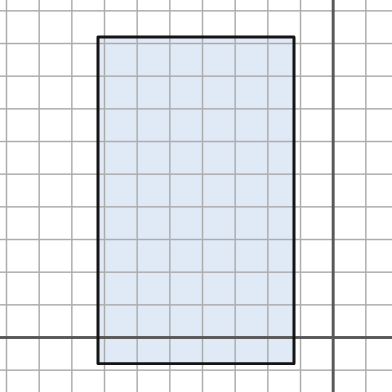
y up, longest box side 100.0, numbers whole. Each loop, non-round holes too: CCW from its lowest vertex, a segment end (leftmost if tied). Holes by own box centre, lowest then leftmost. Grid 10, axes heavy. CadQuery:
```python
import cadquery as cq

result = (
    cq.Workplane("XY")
    .moveTo(-72.0, -8.0)
    .lineTo(-12.0, -8.0)
    .lineTo(-12.0, 92.0)
    .lineTo(-72.0, 92.0)
    .close()
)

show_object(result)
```